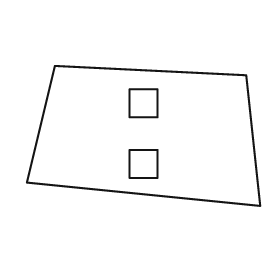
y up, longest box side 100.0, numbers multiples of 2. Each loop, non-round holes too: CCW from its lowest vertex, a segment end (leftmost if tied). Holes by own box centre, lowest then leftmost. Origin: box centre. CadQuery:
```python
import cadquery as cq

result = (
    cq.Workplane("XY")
    .moveTo(50.0, -30.0)
    .lineTo(44.0, 26.0)
    .lineTo(-38.0, 30.0)
    .lineTo(-50.0, -20.0)
    .close()
    .moveTo(-6.0, -18.0)
    .lineTo(6.0, -18.0)
    .lineTo(6.0, -6.0)
    .lineTo(-6.0, -6.0)
    .close()
    .moveTo(-6.0, 8.0)
    .lineTo(6.0, 8.0)
    .lineTo(6.0, 20.0)
    .lineTo(-6.0, 20.0)
    .close()
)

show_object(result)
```